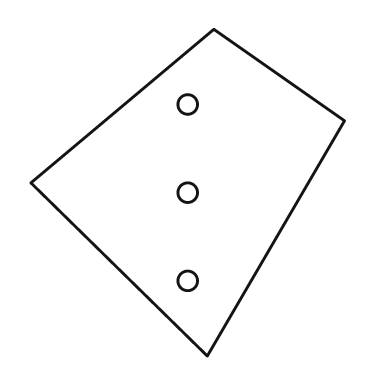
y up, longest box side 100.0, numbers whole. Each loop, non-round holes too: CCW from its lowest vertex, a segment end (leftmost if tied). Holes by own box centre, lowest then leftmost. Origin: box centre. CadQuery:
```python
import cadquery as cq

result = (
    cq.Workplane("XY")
    .moveTo(6.0, -50.0)
    .lineTo(48.0, 22.0)
    .lineTo(8.0, 50.0)
    .lineTo(-48.0, 3.0)
    .close()
    .moveTo(0.0, -27.0)
    .circle(3.0)
    .moveTo(0.0, 0.0)
    .circle(3.0)
    .moveTo(0.0, 27.0)
    .circle(3.0)
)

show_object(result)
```